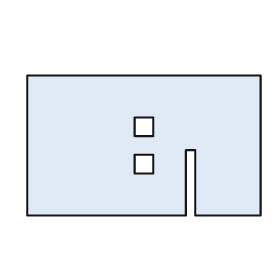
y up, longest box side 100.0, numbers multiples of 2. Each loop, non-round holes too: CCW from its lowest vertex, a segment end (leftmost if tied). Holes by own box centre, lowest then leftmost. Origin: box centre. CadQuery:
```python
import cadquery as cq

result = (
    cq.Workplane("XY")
    .moveTo(-50.0, -30.0)
    .lineTo(18.0, -30.0)
    .lineTo(18.0, -2.0)
    .lineTo(22.0, -2.0)
    .lineTo(22.0, -30.0)
    .lineTo(50.0, -30.0)
    .lineTo(50.0, 30.0)
    .lineTo(-50.0, 30.0)
    .close()
    .moveTo(-4.0, -12.0)
    .lineTo(4.0, -12.0)
    .lineTo(4.0, -4.0)
    .lineTo(-4.0, -4.0)
    .close()
    .moveTo(-4.0, 4.0)
    .lineTo(4.0, 4.0)
    .lineTo(4.0, 12.0)
    .lineTo(-4.0, 12.0)
    .close()
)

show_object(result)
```